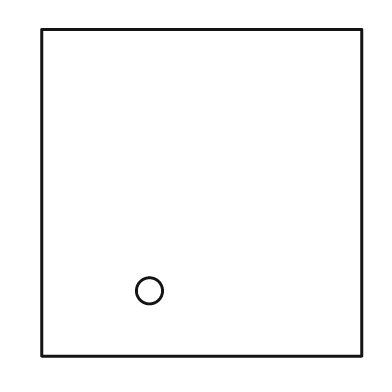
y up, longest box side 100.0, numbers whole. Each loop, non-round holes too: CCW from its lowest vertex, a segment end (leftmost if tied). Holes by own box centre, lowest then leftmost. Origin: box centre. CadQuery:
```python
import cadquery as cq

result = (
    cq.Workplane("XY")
    .moveTo(-49.0, -50.0)
    .lineTo(49.0, -50.0)
    .lineTo(49.0, 50.0)
    .lineTo(-49.0, 50.0)
    .close()
    .moveTo(-16.0, -30.0)
    .circle(4.0)
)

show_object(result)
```